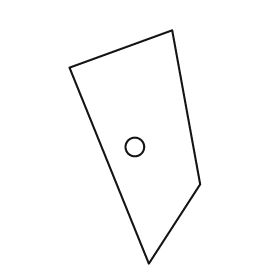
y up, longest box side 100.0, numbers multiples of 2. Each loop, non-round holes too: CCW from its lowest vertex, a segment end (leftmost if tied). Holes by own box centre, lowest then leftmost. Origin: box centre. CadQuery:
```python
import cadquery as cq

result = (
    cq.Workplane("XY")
    .moveTo(6.0, -50.0)
    .lineTo(28.0, -16.0)
    .lineTo(16.0, 50.0)
    .lineTo(-28.0, 34.0)
    .close()
    .moveTo(0.0, 0.0)
    .circle(4.0)
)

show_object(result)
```